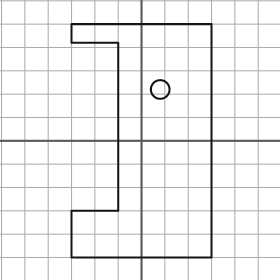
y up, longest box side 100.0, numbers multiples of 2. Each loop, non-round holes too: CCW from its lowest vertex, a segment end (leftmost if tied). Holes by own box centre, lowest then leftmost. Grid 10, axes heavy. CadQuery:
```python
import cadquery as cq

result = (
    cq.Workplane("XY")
    .moveTo(-30.0, -50.0)
    .lineTo(30.0, -50.0)
    .lineTo(30.0, 50.0)
    .lineTo(-30.0, 50.0)
    .lineTo(-30.0, 42.0)
    .lineTo(-10.0, 42.0)
    .lineTo(-10.0, -30.0)
    .lineTo(-30.0, -30.0)
    .close()
    .moveTo(8.0, 22.0)
    .circle(4.0)
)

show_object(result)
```